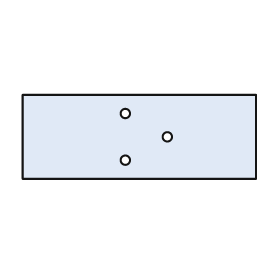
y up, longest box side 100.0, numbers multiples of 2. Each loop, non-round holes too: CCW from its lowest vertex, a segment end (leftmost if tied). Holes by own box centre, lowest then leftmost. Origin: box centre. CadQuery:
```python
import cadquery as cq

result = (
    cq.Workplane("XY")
    .moveTo(-50.0, -18.0)
    .lineTo(50.0, -18.0)
    .lineTo(50.0, 18.0)
    .lineTo(-50.0, 18.0)
    .close()
    .moveTo(-6.0, -10.0)
    .circle(2.0)
    .moveTo(12.0, 0.0)
    .circle(2.0)
    .moveTo(-6.0, 10.0)
    .circle(2.0)
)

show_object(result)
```